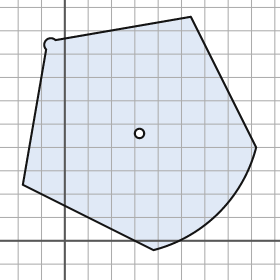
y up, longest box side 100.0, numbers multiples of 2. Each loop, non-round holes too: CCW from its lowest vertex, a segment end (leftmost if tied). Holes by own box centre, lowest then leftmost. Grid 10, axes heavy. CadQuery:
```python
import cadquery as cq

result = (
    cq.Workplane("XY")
    .moveTo(38.0, -4.0)
    .threePointArc((66.0, 12.0), (82.0, 40.0))
    .lineTo(54.0, 96.0)
    .lineTo(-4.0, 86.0)
    .threePointArc((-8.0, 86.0), (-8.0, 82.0))
    .lineTo(-18.0, 24.0)
    .close()
    .moveTo(32.0, 46.0)
    .circle(2.0)
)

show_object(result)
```